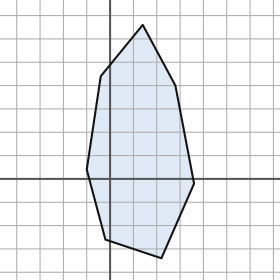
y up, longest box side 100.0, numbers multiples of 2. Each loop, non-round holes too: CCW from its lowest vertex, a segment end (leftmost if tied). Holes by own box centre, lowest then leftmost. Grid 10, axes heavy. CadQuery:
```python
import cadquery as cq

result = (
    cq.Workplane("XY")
    .moveTo(22.0, -34.0)
    .lineTo(36.0, -2.0)
    .lineTo(28.0, 40.0)
    .lineTo(14.0, 66.0)
    .lineTo(-4.0, 44.0)
    .lineTo(-10.0, 4.0)
    .lineTo(-2.0, -26.0)
    .close()
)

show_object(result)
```